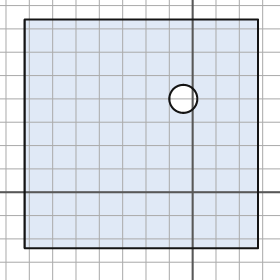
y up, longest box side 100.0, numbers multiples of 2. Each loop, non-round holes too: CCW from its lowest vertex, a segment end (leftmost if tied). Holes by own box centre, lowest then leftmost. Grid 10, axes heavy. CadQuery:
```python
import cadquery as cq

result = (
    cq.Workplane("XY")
    .moveTo(-72.0, -24.0)
    .lineTo(28.0, -24.0)
    .lineTo(28.0, 74.0)
    .lineTo(-72.0, 74.0)
    .close()
    .moveTo(-4.0, 40.0)
    .circle(6.0)
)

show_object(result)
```